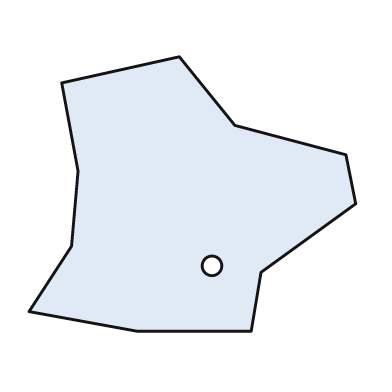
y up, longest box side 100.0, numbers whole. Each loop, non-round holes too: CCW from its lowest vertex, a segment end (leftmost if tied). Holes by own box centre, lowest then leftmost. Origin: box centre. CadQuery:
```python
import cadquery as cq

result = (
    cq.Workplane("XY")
    .moveTo(-17.0, -42.0)
    .lineTo(18.0, -42.0)
    .lineTo(21.0, -24.0)
    .lineTo(50.0, -3.0)
    .lineTo(47.0, 12.0)
    .lineTo(13.0, 21.0)
    .lineTo(-4.0, 42.0)
    .lineTo(-40.0, 34.0)
    .lineTo(-35.0, 7.0)
    .lineTo(-37.0, -16.0)
    .lineTo(-50.0, -36.0)
    .close()
    .moveTo(6.0, -22.0)
    .circle(3.0)
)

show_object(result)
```